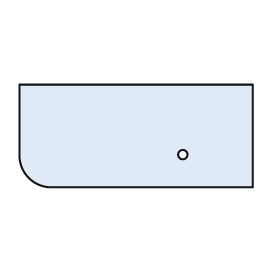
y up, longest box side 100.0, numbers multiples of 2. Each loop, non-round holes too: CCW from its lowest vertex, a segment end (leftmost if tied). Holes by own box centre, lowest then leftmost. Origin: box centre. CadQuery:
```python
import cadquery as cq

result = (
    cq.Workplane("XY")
    .moveTo(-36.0, -22.0)
    .lineTo(50.0, -22.0)
    .lineTo(50.0, 22.0)
    .lineTo(-50.0, 22.0)
    .lineTo(-50.0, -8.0)
    .threePointArc((-46.0, -18.0), (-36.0, -22.0))
    .close()
    .moveTo(20.0, -8.0)
    .circle(2.0)
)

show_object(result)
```